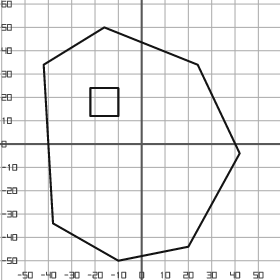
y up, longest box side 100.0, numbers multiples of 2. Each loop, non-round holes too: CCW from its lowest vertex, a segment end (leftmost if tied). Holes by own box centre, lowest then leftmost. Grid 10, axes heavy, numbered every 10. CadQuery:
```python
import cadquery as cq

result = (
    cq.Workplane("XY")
    .moveTo(-10.0, -50.0)
    .lineTo(20.0, -44.0)
    .lineTo(42.0, -4.0)
    .lineTo(24.0, 34.0)
    .lineTo(-16.0, 50.0)
    .lineTo(-42.0, 34.0)
    .lineTo(-38.0, -34.0)
    .close()
    .moveTo(-22.0, 12.0)
    .lineTo(-10.0, 12.0)
    .lineTo(-10.0, 24.0)
    .lineTo(-22.0, 24.0)
    .close()
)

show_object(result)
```